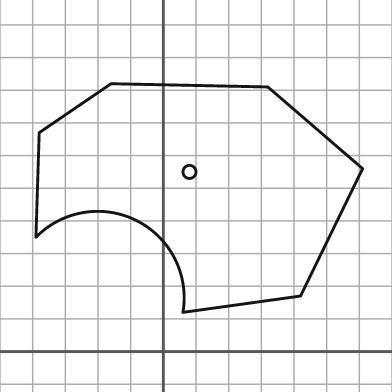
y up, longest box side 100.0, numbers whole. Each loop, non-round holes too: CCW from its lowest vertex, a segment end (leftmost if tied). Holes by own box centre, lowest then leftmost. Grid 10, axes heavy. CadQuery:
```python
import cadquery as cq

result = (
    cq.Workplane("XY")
    .moveTo(6.0, 12.0)
    .lineTo(42.0, 17.0)
    .lineTo(61.0, 56.0)
    .lineTo(32.0, 81.0)
    .lineTo(-16.0, 82.0)
    .lineTo(-38.0, 67.0)
    .lineTo(-39.0, 35.0)
    .threePointArc((-8.0, 40.0), (6.0, 12.0))
    .close()
    .moveTo(8.0, 55.0)
    .circle(2.0)
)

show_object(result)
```